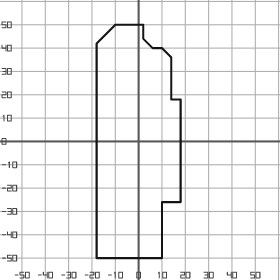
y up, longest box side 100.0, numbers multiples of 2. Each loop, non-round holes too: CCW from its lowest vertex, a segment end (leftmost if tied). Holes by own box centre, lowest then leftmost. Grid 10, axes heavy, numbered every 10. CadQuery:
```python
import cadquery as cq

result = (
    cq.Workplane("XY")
    .moveTo(-18.0, -50.0)
    .lineTo(10.0, -50.0)
    .lineTo(10.0, -26.0)
    .lineTo(18.0, -26.0)
    .lineTo(18.0, 18.0)
    .lineTo(14.0, 18.0)
    .lineTo(14.0, 36.0)
    .lineTo(10.0, 40.0)
    .lineTo(6.0, 40.0)
    .lineTo(2.0, 44.0)
    .lineTo(2.0, 50.0)
    .lineTo(-10.0, 50.0)
    .lineTo(-18.0, 42.0)
    .close()
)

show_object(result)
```